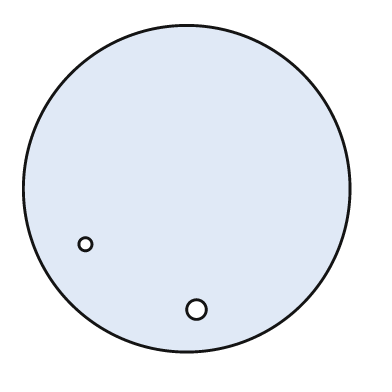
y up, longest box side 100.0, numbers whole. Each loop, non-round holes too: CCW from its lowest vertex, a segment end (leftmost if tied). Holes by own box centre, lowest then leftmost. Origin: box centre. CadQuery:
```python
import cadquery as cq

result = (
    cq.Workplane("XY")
    .moveTo(0.0, 0.0)
    .circle(50.0)
    .moveTo(3.0, -37.0)
    .circle(3.0)
    .moveTo(-31.0, -17.0)
    .circle(2.0)
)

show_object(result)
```